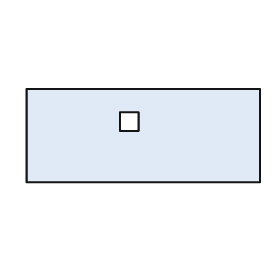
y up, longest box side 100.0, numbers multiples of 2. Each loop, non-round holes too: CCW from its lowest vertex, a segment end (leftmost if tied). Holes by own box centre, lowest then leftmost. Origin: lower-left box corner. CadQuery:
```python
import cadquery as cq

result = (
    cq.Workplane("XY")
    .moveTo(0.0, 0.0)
    .lineTo(100.0, 0.0)
    .lineTo(100.0, 40.0)
    .lineTo(0.0, 40.0)
    .close()
    .moveTo(40.0, 22.0)
    .lineTo(48.0, 22.0)
    .lineTo(48.0, 30.0)
    .lineTo(40.0, 30.0)
    .close()
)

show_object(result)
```